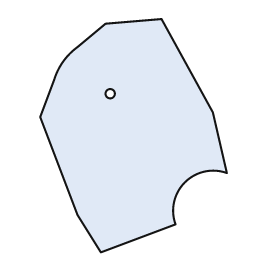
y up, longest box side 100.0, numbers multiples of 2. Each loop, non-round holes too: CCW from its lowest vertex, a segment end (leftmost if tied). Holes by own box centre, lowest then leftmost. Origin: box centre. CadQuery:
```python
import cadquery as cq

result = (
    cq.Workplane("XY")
    .moveTo(-14.0, -50.0)
    .lineTo(18.0, -38.0)
    .threePointArc((22.0, -20.0), (40.0, -16.0))
    .lineTo(34.0, 10.0)
    .lineTo(12.0, 50.0)
    .lineTo(-12.0, 48.0)
    .lineTo(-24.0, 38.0)
    .threePointArc((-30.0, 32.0), (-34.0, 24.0))
    .lineTo(-40.0, 8.0)
    .lineTo(-24.0, -34.0)
    .close()
    .moveTo(-10.0, 18.0)
    .circle(2.0)
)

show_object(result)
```